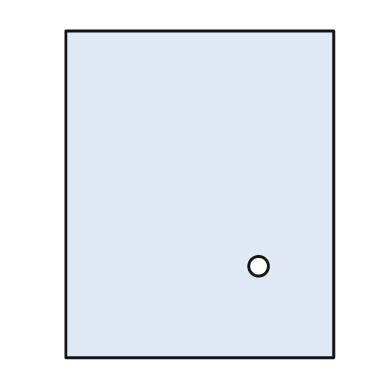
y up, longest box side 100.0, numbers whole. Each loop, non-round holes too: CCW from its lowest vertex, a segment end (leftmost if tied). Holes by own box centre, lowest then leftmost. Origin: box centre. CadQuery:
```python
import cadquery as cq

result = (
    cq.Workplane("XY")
    .moveTo(-41.0, -50.0)
    .lineTo(41.0, -50.0)
    .lineTo(41.0, 50.0)
    .lineTo(-41.0, 50.0)
    .close()
    .moveTo(18.0, -22.0)
    .circle(3.0)
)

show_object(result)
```